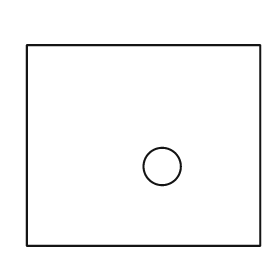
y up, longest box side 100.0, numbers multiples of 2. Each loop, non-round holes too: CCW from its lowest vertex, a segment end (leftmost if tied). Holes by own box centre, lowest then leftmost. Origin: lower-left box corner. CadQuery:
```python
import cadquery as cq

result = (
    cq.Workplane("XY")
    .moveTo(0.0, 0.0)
    .lineTo(100.0, 0.0)
    .lineTo(100.0, 86.0)
    .lineTo(0.0, 86.0)
    .close()
    .moveTo(58.0, 34.0)
    .circle(8.0)
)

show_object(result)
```